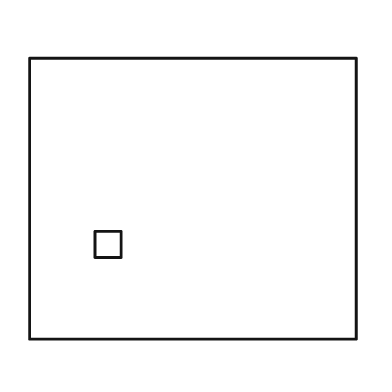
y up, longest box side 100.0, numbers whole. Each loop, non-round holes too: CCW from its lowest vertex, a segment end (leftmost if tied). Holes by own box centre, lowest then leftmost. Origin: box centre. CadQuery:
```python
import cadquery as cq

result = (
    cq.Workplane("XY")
    .moveTo(-50.0, -43.0)
    .lineTo(50.0, -43.0)
    .lineTo(50.0, 43.0)
    .lineTo(-50.0, 43.0)
    .close()
    .moveTo(-30.0, -18.0)
    .lineTo(-22.0, -18.0)
    .lineTo(-22.0, -10.0)
    .lineTo(-30.0, -10.0)
    .close()
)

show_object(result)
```